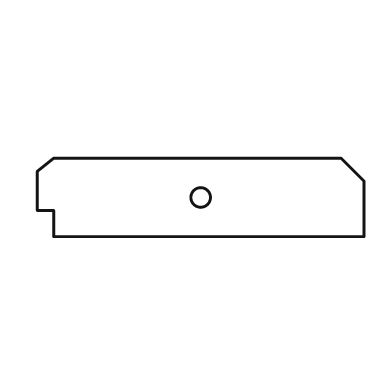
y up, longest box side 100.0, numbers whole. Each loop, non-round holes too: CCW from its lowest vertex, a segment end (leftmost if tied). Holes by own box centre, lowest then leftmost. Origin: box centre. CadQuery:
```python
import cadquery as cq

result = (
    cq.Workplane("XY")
    .moveTo(-45.0, -12.0)
    .lineTo(50.0, -12.0)
    .lineTo(50.0, 5.0)
    .lineTo(43.0, 12.0)
    .lineTo(-45.0, 12.0)
    .lineTo(-50.0, 8.0)
    .lineTo(-50.0, -4.0)
    .lineTo(-45.0, -4.0)
    .close()
    .moveTo(0.0, 0.0)
    .circle(3.0)
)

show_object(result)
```